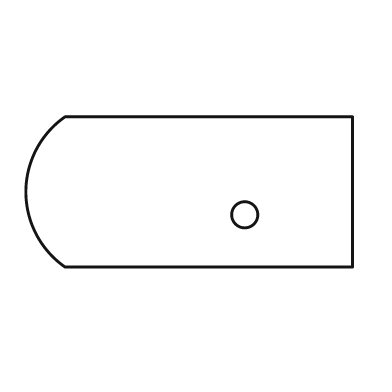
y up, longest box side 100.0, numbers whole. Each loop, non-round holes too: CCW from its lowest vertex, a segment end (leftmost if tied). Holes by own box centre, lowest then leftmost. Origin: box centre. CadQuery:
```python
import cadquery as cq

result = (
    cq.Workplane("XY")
    .moveTo(-38.0, -23.0)
    .lineTo(50.0, -23.0)
    .lineTo(50.0, 23.0)
    .lineTo(-38.0, 23.0)
    .threePointArc((-50.0, 0.0), (-38.0, -23.0))
    .close()
    .moveTo(17.0, -7.0)
    .circle(4.0)
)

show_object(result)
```